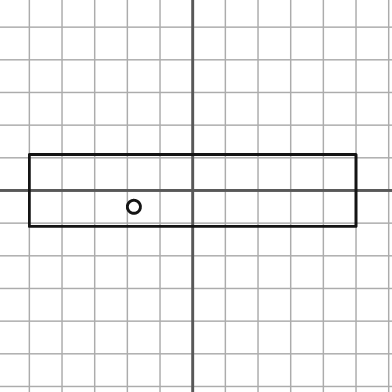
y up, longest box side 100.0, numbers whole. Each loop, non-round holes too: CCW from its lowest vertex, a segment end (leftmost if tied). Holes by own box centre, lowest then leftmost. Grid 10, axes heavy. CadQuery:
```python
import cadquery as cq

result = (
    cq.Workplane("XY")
    .moveTo(-50.0, -11.0)
    .lineTo(50.0, -11.0)
    .lineTo(50.0, 11.0)
    .lineTo(-50.0, 11.0)
    .close()
    .moveTo(-18.0, -5.0)
    .circle(2.0)
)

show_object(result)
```